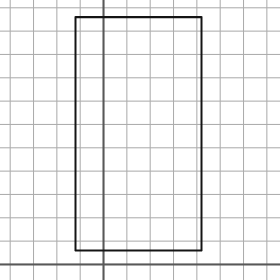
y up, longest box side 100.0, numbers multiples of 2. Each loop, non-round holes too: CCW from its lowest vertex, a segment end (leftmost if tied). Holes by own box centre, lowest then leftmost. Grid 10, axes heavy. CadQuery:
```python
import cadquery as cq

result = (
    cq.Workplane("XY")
    .moveTo(-12.0, 6.0)
    .lineTo(42.0, 6.0)
    .lineTo(42.0, 106.0)
    .lineTo(-12.0, 106.0)
    .close()
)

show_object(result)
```